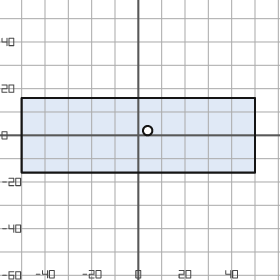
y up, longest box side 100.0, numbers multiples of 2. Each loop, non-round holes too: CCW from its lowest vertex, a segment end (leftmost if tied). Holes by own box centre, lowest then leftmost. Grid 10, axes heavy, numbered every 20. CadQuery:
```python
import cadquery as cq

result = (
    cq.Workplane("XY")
    .moveTo(-50.0, -16.0)
    .lineTo(50.0, -16.0)
    .lineTo(50.0, 16.0)
    .lineTo(-50.0, 16.0)
    .close()
    .moveTo(4.0, 2.0)
    .circle(2.0)
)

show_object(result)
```